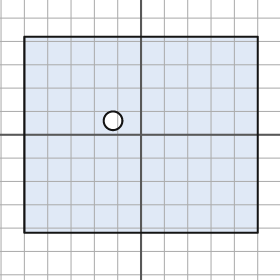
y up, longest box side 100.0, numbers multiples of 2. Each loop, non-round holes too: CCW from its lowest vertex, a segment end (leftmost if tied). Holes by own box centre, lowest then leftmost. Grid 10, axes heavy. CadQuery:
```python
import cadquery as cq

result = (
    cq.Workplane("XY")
    .moveTo(-50.0, -42.0)
    .lineTo(50.0, -42.0)
    .lineTo(50.0, 42.0)
    .lineTo(-50.0, 42.0)
    .close()
    .moveTo(-12.0, 6.0)
    .circle(4.0)
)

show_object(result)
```